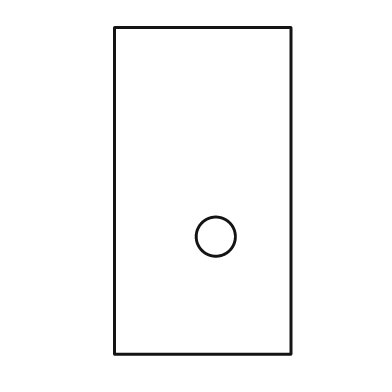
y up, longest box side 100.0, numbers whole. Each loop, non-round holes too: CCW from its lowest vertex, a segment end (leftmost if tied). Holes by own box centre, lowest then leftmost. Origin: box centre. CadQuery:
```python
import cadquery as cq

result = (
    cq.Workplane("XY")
    .moveTo(-27.0, -50.0)
    .lineTo(27.0, -50.0)
    .lineTo(27.0, 50.0)
    .lineTo(-27.0, 50.0)
    .close()
    .moveTo(4.0, -14.0)
    .circle(6.0)
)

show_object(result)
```